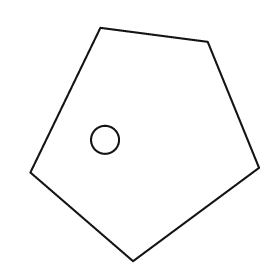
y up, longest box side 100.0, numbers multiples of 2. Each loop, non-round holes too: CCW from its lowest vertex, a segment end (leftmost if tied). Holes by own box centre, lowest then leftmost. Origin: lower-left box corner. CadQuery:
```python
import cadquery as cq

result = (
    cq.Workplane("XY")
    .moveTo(44.0, 0.0)
    .lineTo(98.0, 40.0)
    .lineTo(76.0, 94.0)
    .lineTo(30.0, 100.0)
    .lineTo(0.0, 38.0)
    .close()
    .moveTo(32.0, 52.0)
    .circle(6.0)
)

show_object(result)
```